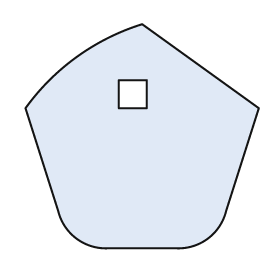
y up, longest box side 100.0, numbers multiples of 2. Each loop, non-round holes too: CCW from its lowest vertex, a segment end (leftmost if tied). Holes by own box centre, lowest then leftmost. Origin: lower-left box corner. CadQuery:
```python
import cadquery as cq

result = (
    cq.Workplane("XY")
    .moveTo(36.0, 0.0)
    .lineTo(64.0, 0.0)
    .threePointArc((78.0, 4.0), (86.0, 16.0))
    .lineTo(100.0, 60.0)
    .lineTo(50.0, 96.0)
    .threePointArc((22.0, 82.0), (0.0, 60.0))
    .lineTo(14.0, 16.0)
    .threePointArc((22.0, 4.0), (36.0, 0.0))
    .close()
    .moveTo(40.0, 60.0)
    .lineTo(52.0, 60.0)
    .lineTo(52.0, 72.0)
    .lineTo(40.0, 72.0)
    .close()
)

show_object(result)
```